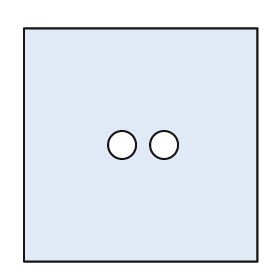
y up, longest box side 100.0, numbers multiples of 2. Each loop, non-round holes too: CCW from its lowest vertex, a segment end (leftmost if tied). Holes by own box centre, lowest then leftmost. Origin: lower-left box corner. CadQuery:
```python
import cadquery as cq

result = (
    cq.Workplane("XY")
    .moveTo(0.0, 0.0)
    .lineTo(100.0, 0.0)
    .lineTo(100.0, 100.0)
    .lineTo(0.0, 100.0)
    .close()
    .moveTo(42.0, 50.0)
    .circle(6.0)
    .moveTo(60.0, 50.0)
    .circle(6.0)
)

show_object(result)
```